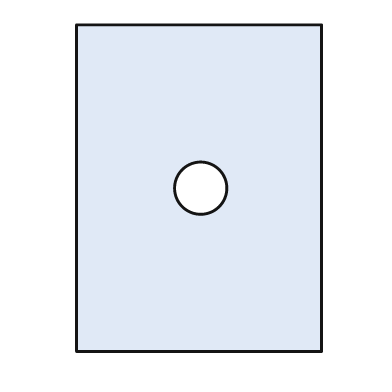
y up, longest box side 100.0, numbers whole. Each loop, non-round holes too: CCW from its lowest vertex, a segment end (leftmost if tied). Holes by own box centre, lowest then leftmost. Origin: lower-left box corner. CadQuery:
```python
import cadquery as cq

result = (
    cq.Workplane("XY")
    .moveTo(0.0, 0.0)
    .lineTo(75.0, 0.0)
    .lineTo(75.0, 100.0)
    .lineTo(0.0, 100.0)
    .close()
    .moveTo(38.0, 50.0)
    .circle(8.0)
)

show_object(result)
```